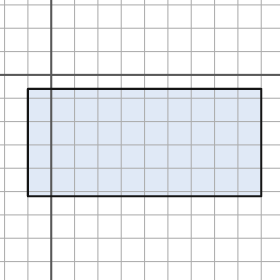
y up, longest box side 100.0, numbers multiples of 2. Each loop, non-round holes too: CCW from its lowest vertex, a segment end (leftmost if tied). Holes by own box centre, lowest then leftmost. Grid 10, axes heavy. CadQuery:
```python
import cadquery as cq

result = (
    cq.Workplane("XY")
    .moveTo(-10.0, -52.0)
    .lineTo(90.0, -52.0)
    .lineTo(90.0, -6.0)
    .lineTo(-10.0, -6.0)
    .close()
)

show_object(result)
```